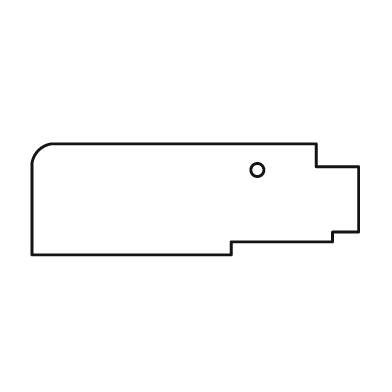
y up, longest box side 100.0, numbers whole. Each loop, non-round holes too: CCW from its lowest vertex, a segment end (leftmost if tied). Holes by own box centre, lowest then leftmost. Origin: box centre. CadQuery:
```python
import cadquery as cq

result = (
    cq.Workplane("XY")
    .moveTo(-50.0, -17.0)
    .lineTo(11.0, -17.0)
    .lineTo(11.0, -13.0)
    .lineTo(42.0, -13.0)
    .lineTo(42.0, -10.0)
    .lineTo(50.0, -10.0)
    .lineTo(50.0, 10.0)
    .lineTo(37.0, 10.0)
    .lineTo(37.0, 17.0)
    .lineTo(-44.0, 17.0)
    .threePointArc((-48.0, 15.0), (-50.0, 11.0))
    .close()
    .moveTo(19.0, 9.0)
    .circle(2.0)
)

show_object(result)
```